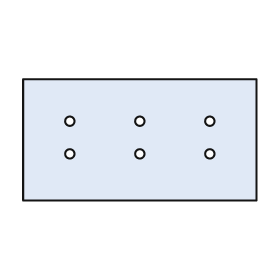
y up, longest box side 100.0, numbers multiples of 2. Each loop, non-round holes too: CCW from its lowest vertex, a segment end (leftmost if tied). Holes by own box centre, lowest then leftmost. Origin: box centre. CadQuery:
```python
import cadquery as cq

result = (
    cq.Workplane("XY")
    .moveTo(-50.0, -26.0)
    .lineTo(50.0, -26.0)
    .lineTo(50.0, 26.0)
    .lineTo(-50.0, 26.0)
    .close()
    .moveTo(-30.0, -6.0)
    .circle(2.0)
    .moveTo(0.0, -6.0)
    .circle(2.0)
    .moveTo(30.0, -6.0)
    .circle(2.0)
    .moveTo(-30.0, 8.0)
    .circle(2.0)
    .moveTo(0.0, 8.0)
    .circle(2.0)
    .moveTo(30.0, 8.0)
    .circle(2.0)
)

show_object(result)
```